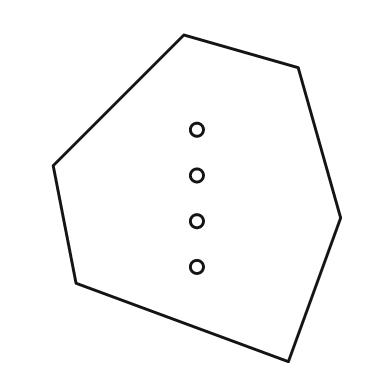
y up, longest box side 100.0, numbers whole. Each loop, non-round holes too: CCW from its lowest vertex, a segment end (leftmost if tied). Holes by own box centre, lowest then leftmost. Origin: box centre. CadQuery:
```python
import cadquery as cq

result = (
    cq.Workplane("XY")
    .moveTo(28.0, -50.0)
    .lineTo(44.0, -6.0)
    .lineTo(31.0, 40.0)
    .lineTo(-4.0, 50.0)
    .lineTo(-44.0, 10.0)
    .lineTo(-37.0, -26.0)
    .close()
    .moveTo(0.0, -21.0)
    .circle(2.0)
    .moveTo(0.0, -7.0)
    .circle(2.0)
    .moveTo(0.0, 7.0)
    .circle(2.0)
    .moveTo(0.0, 21.0)
    .circle(2.0)
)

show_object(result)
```